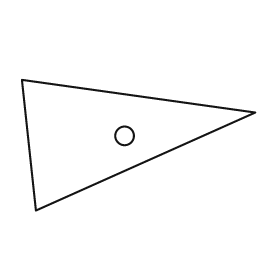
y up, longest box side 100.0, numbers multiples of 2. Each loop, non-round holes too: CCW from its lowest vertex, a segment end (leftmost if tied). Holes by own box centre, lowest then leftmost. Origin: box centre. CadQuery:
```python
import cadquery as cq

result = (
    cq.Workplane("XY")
    .moveTo(-44.0, -28.0)
    .lineTo(50.0, 14.0)
    .lineTo(-50.0, 28.0)
    .close()
    .moveTo(-6.0, 4.0)
    .circle(4.0)
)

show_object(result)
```